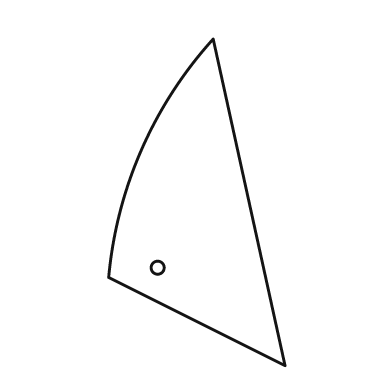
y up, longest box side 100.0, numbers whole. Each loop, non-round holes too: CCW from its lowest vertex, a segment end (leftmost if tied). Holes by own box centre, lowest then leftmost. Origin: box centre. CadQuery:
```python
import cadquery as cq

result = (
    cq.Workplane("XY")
    .moveTo(27.0, -50.0)
    .lineTo(5.0, 50.0)
    .threePointArc((-17.0, 16.0), (-27.0, -23.0))
    .close()
    .moveTo(-12.0, -20.0)
    .circle(2.0)
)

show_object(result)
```